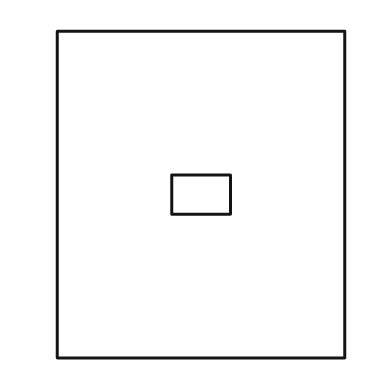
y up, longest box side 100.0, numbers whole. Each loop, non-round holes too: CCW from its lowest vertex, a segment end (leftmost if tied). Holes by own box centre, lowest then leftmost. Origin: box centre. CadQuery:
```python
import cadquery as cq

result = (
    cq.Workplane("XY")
    .moveTo(-44.0, -50.0)
    .lineTo(44.0, -50.0)
    .lineTo(44.0, 50.0)
    .lineTo(-44.0, 50.0)
    .close()
    .moveTo(-9.0, -6.0)
    .lineTo(9.0, -6.0)
    .lineTo(9.0, 6.0)
    .lineTo(-9.0, 6.0)
    .close()
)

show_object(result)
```